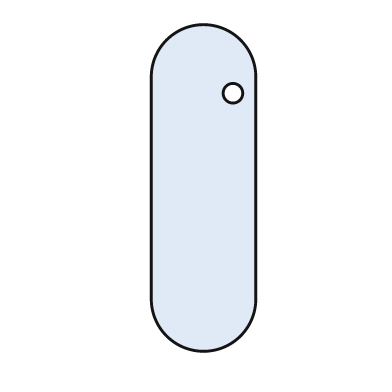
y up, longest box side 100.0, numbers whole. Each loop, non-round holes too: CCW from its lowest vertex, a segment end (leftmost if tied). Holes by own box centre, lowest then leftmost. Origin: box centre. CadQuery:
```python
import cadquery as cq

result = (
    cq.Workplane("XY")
    .moveTo(-16.0, -34.0)
    .threePointArc((0.0, -50.0), (16.0, -34.0))
    .lineTo(16.0, 34.0)
    .threePointArc((0.0, 50.0), (-16.0, 34.0))
    .close()
    .moveTo(9.0, 29.0)
    .circle(3.0)
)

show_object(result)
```